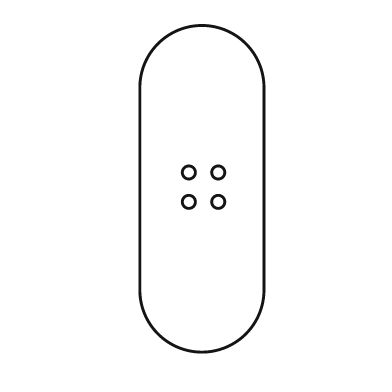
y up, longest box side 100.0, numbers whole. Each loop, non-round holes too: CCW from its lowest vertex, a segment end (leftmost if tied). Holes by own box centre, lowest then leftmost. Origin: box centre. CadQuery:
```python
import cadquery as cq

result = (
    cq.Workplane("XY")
    .moveTo(-19.0, -31.0)
    .threePointArc((0.0, -50.0), (19.0, -31.0))
    .lineTo(19.0, 31.0)
    .threePointArc((0.0, 50.0), (-19.0, 31.0))
    .close()
    .moveTo(-4.0, -4.0)
    .circle(2.0)
    .moveTo(5.0, -4.0)
    .circle(2.0)
    .moveTo(-4.0, 5.0)
    .circle(2.0)
    .moveTo(5.0, 5.0)
    .circle(2.0)
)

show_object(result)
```